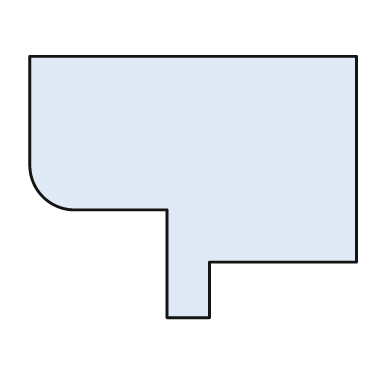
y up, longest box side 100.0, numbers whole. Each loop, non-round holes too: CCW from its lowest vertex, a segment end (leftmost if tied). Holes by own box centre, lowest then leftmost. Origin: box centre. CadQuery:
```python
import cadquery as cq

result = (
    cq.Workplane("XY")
    .moveTo(-8.0, -40.0)
    .lineTo(5.0, -40.0)
    .lineTo(5.0, -23.0)
    .lineTo(50.0, -23.0)
    .lineTo(50.0, 40.0)
    .lineTo(-50.0, 40.0)
    .lineTo(-50.0, 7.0)
    .threePointArc((-46.0, -3.0), (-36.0, -7.0))
    .lineTo(-8.0, -7.0)
    .close()
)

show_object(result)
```